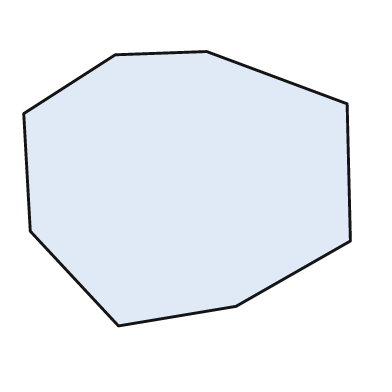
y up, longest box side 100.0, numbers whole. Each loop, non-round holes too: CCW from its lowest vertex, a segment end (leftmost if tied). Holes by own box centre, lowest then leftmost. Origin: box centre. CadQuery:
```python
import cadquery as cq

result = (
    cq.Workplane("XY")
    .moveTo(-21.0, -42.0)
    .lineTo(15.0, -36.0)
    .lineTo(50.0, -16.0)
    .lineTo(49.0, 26.0)
    .lineTo(6.0, 42.0)
    .lineTo(-22.0, 41.0)
    .lineTo(-50.0, 23.0)
    .lineTo(-48.0, -13.0)
    .close()
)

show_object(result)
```